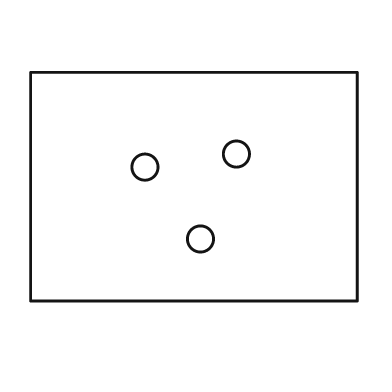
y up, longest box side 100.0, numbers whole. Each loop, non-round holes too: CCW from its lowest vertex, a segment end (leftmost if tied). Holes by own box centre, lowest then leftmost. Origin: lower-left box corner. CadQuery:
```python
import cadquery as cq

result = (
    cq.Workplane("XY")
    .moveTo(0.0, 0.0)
    .lineTo(100.0, 0.0)
    .lineTo(100.0, 70.0)
    .lineTo(0.0, 70.0)
    .close()
    .moveTo(52.0, 19.0)
    .circle(4.0)
    .moveTo(35.0, 41.0)
    .circle(4.0)
    .moveTo(63.0, 45.0)
    .circle(4.0)
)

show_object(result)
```